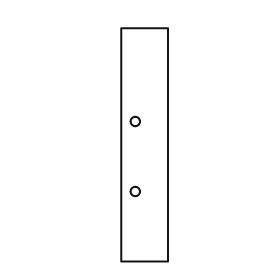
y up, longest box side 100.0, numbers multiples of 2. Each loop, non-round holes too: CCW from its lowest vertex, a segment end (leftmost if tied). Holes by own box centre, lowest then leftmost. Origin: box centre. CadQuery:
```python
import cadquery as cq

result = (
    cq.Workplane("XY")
    .moveTo(-10.0, -50.0)
    .lineTo(10.0, -50.0)
    .lineTo(10.0, 50.0)
    .lineTo(-10.0, 50.0)
    .close()
    .moveTo(-4.0, -20.0)
    .circle(2.0)
    .moveTo(-4.0, 10.0)
    .circle(2.0)
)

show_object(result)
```